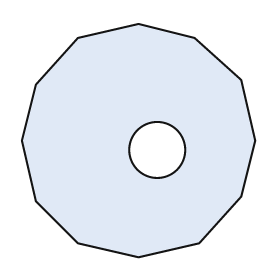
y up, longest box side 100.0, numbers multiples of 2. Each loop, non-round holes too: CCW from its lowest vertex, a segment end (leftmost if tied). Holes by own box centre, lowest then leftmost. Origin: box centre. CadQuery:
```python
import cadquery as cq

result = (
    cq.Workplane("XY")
    .moveTo(0.0, -50.0)
    .lineTo(26.0, -44.0)
    .lineTo(44.0, -24.0)
    .lineTo(50.0, 0.0)
    .lineTo(44.0, 26.0)
    .lineTo(24.0, 44.0)
    .lineTo(0.0, 50.0)
    .lineTo(-26.0, 44.0)
    .lineTo(-44.0, 24.0)
    .lineTo(-50.0, 0.0)
    .lineTo(-44.0, -26.0)
    .lineTo(-26.0, -44.0)
    .close()
    .moveTo(8.0, -4.0)
    .circle(12.0)
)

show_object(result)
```